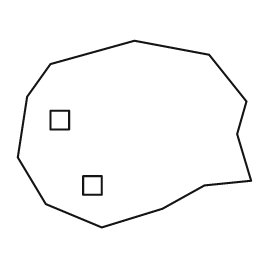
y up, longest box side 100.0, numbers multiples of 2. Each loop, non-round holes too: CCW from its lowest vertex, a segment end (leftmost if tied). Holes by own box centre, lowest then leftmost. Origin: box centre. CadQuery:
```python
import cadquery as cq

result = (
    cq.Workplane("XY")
    .moveTo(-14.0, -40.0)
    .lineTo(12.0, -32.0)
    .lineTo(30.0, -22.0)
    .lineTo(50.0, -20.0)
    .lineTo(44.0, 0.0)
    .lineTo(48.0, 14.0)
    .lineTo(32.0, 34.0)
    .lineTo(0.0, 40.0)
    .lineTo(-36.0, 30.0)
    .lineTo(-46.0, 16.0)
    .lineTo(-50.0, -10.0)
    .lineTo(-38.0, -30.0)
    .close()
    .moveTo(-22.0, -26.0)
    .lineTo(-14.0, -26.0)
    .lineTo(-14.0, -18.0)
    .lineTo(-22.0, -18.0)
    .close()
    .moveTo(-36.0, 2.0)
    .lineTo(-28.0, 2.0)
    .lineTo(-28.0, 10.0)
    .lineTo(-36.0, 10.0)
    .close()
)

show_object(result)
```